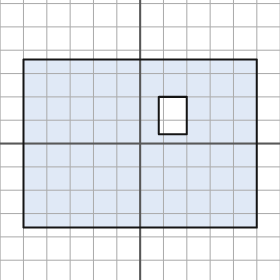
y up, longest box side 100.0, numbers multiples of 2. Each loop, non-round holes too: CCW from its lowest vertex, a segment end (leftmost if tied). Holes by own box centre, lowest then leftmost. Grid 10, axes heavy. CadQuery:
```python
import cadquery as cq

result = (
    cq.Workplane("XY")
    .moveTo(-50.0, -36.0)
    .lineTo(50.0, -36.0)
    .lineTo(50.0, 36.0)
    .lineTo(-50.0, 36.0)
    .close()
    .moveTo(8.0, 4.0)
    .lineTo(20.0, 4.0)
    .lineTo(20.0, 20.0)
    .lineTo(8.0, 20.0)
    .close()
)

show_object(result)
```